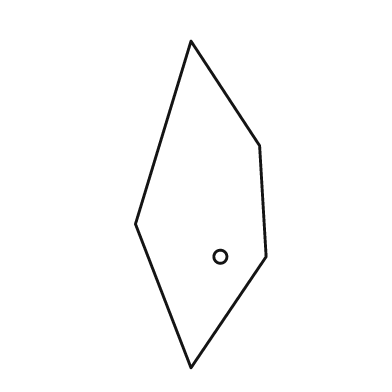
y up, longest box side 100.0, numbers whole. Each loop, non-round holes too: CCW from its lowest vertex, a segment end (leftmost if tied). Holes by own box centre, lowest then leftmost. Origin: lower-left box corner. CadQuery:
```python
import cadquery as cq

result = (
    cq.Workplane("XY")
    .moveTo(17.0, 0.0)
    .lineTo(40.0, 34.0)
    .lineTo(38.0, 68.0)
    .lineTo(17.0, 100.0)
    .lineTo(0.0, 44.0)
    .close()
    .moveTo(26.0, 34.0)
    .circle(2.0)
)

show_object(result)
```